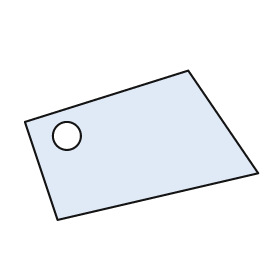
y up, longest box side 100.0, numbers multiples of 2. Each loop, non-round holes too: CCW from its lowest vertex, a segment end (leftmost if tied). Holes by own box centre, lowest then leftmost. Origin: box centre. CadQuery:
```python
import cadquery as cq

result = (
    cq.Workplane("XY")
    .moveTo(-36.0, -32.0)
    .lineTo(50.0, -12.0)
    .lineTo(20.0, 32.0)
    .lineTo(-50.0, 10.0)
    .close()
    .moveTo(-32.0, 4.0)
    .circle(6.0)
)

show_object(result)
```